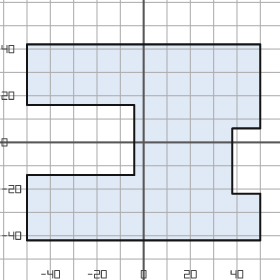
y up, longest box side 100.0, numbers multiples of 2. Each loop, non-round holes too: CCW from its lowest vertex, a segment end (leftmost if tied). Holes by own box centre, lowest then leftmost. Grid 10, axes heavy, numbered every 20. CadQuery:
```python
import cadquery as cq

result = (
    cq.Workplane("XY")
    .moveTo(-50.0, -42.0)
    .lineTo(50.0, -42.0)
    .lineTo(50.0, -22.0)
    .lineTo(38.0, -22.0)
    .lineTo(38.0, 6.0)
    .lineTo(50.0, 6.0)
    .lineTo(50.0, 42.0)
    .lineTo(-50.0, 42.0)
    .lineTo(-50.0, 16.0)
    .lineTo(-4.0, 16.0)
    .lineTo(-4.0, -14.0)
    .lineTo(-50.0, -14.0)
    .close()
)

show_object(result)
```